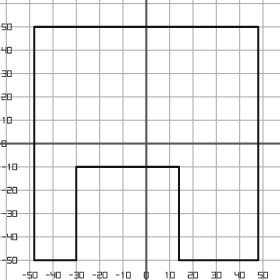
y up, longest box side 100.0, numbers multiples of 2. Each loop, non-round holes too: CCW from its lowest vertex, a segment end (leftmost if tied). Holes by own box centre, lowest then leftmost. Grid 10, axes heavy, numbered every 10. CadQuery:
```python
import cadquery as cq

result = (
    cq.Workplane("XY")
    .moveTo(-48.0, -50.0)
    .lineTo(-30.0, -50.0)
    .lineTo(-30.0, -10.0)
    .lineTo(14.0, -10.0)
    .lineTo(14.0, -50.0)
    .lineTo(48.0, -50.0)
    .lineTo(48.0, 50.0)
    .lineTo(-48.0, 50.0)
    .close()
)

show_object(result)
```